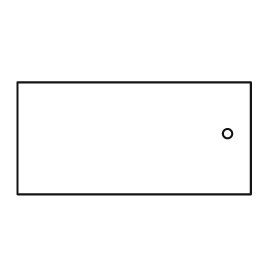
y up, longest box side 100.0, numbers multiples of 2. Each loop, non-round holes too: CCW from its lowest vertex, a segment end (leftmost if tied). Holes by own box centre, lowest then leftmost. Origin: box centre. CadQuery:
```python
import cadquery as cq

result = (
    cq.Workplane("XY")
    .moveTo(-50.0, -24.0)
    .lineTo(50.0, -24.0)
    .lineTo(50.0, 24.0)
    .lineTo(-50.0, 24.0)
    .close()
    .moveTo(40.0, 2.0)
    .circle(2.0)
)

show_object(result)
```